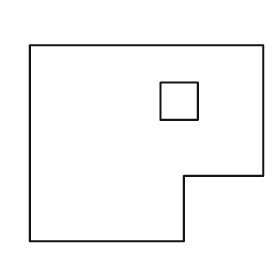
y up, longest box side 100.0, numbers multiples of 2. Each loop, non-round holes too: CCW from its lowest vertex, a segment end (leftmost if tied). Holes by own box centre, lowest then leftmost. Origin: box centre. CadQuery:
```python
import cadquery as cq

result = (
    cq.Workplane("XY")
    .moveTo(-50.0, -42.0)
    .lineTo(16.0, -42.0)
    .lineTo(16.0, -14.0)
    .lineTo(50.0, -14.0)
    .lineTo(50.0, 42.0)
    .lineTo(-50.0, 42.0)
    .close()
    .moveTo(6.0, 10.0)
    .lineTo(22.0, 10.0)
    .lineTo(22.0, 26.0)
    .lineTo(6.0, 26.0)
    .close()
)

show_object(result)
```